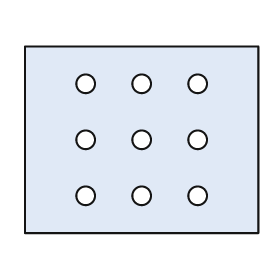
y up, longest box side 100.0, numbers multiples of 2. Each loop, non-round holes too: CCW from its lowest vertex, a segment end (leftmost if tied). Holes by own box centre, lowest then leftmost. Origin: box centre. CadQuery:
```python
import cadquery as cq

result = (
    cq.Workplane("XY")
    .moveTo(-50.0, -40.0)
    .lineTo(50.0, -40.0)
    .lineTo(50.0, 40.0)
    .lineTo(-50.0, 40.0)
    .close()
    .moveTo(-24.0, -24.0)
    .circle(4.0)
    .moveTo(0.0, -24.0)
    .circle(4.0)
    .moveTo(24.0, -24.0)
    .circle(4.0)
    .moveTo(-24.0, 0.0)
    .circle(4.0)
    .moveTo(0.0, 0.0)
    .circle(4.0)
    .moveTo(24.0, 0.0)
    .circle(4.0)
    .moveTo(-24.0, 24.0)
    .circle(4.0)
    .moveTo(0.0, 24.0)
    .circle(4.0)
    .moveTo(24.0, 24.0)
    .circle(4.0)
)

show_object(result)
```